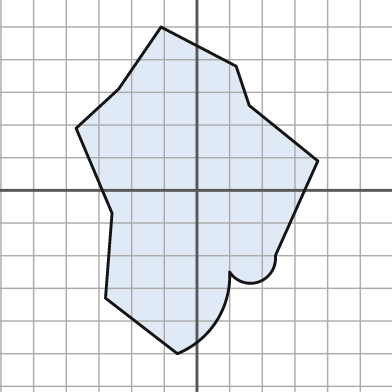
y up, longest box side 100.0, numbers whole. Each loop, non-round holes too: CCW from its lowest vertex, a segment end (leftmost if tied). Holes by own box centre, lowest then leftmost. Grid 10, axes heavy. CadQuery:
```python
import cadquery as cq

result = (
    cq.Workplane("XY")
    .moveTo(-6.0, -50.0)
    .threePointArc((6.0, -40.0), (10.0, -25.0))
    .threePointArc((19.0, -28.0), (24.0, -20.0))
    .lineTo(37.0, 9.0)
    .lineTo(16.0, 26.0)
    .lineTo(12.0, 38.0)
    .lineTo(-11.0, 50.0)
    .lineTo(-24.0, 31.0)
    .lineTo(-37.0, 19.0)
    .lineTo(-26.0, -7.0)
    .lineTo(-28.0, -33.0)
    .close()
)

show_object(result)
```